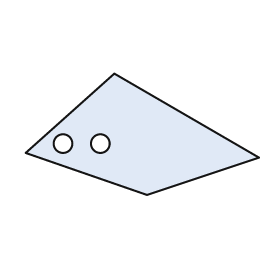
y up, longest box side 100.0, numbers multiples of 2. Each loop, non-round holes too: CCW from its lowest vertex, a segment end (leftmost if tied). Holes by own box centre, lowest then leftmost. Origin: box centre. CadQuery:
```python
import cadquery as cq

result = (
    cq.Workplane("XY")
    .moveTo(2.0, -26.0)
    .lineTo(50.0, -10.0)
    .lineTo(-12.0, 26.0)
    .lineTo(-50.0, -8.0)
    .close()
    .moveTo(-34.0, -4.0)
    .circle(4.0)
    .moveTo(-18.0, -4.0)
    .circle(4.0)
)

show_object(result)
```